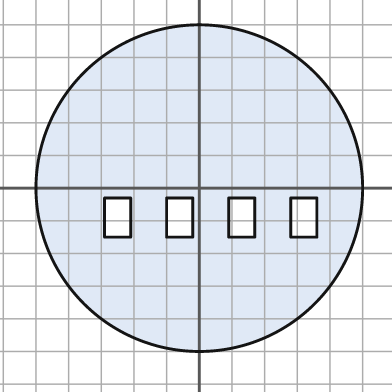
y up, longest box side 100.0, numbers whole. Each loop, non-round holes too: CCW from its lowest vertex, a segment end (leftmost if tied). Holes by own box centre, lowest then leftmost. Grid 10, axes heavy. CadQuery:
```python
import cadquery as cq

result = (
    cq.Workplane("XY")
    .moveTo(0.0, 0.0)
    .circle(50.0)
    .moveTo(-29.0, -15.0)
    .lineTo(-21.0, -15.0)
    .lineTo(-21.0, -3.0)
    .lineTo(-29.0, -3.0)
    .close()
    .moveTo(-10.0, -15.0)
    .lineTo(-2.0, -15.0)
    .lineTo(-2.0, -3.0)
    .lineTo(-10.0, -3.0)
    .close()
    .moveTo(9.0, -15.0)
    .lineTo(17.0, -15.0)
    .lineTo(17.0, -3.0)
    .lineTo(9.0, -3.0)
    .close()
    .moveTo(28.0, -15.0)
    .lineTo(36.0, -15.0)
    .lineTo(36.0, -3.0)
    .lineTo(28.0, -3.0)
    .close()
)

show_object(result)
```